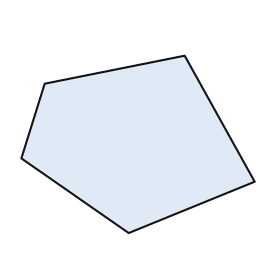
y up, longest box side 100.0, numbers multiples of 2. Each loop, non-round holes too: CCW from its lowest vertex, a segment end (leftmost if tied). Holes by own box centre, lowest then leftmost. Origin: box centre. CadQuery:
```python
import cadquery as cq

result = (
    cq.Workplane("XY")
    .moveTo(-4.0, -38.0)
    .lineTo(50.0, -16.0)
    .lineTo(20.0, 38.0)
    .lineTo(-40.0, 26.0)
    .lineTo(-50.0, -6.0)
    .close()
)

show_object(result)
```